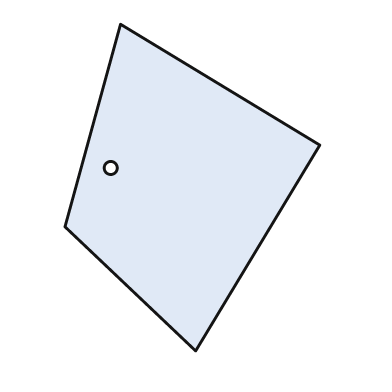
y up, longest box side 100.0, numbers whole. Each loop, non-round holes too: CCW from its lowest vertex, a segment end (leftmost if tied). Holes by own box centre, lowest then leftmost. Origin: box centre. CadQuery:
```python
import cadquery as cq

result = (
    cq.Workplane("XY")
    .moveTo(1.0, -50.0)
    .lineTo(39.0, 13.0)
    .lineTo(-22.0, 50.0)
    .lineTo(-39.0, -12.0)
    .close()
    .moveTo(-25.0, 6.0)
    .circle(2.0)
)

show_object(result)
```